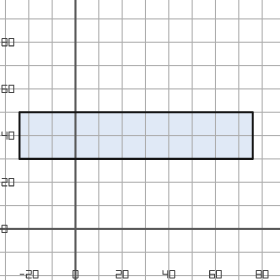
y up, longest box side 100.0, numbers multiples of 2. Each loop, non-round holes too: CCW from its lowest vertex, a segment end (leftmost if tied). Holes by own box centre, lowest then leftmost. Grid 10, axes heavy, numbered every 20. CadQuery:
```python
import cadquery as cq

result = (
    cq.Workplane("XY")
    .moveTo(-24.0, 30.0)
    .lineTo(76.0, 30.0)
    .lineTo(76.0, 50.0)
    .lineTo(-24.0, 50.0)
    .close()
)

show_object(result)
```